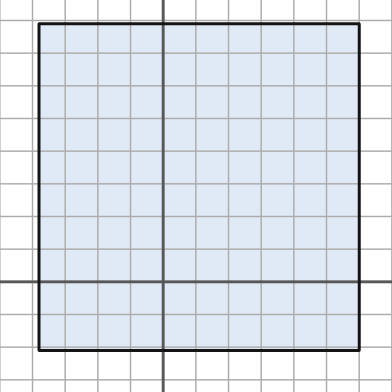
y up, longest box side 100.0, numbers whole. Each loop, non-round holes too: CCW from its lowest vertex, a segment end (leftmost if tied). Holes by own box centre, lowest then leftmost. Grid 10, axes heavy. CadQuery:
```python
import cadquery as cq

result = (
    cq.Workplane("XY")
    .moveTo(-38.0, -21.0)
    .lineTo(60.0, -21.0)
    .lineTo(60.0, 79.0)
    .lineTo(-38.0, 79.0)
    .close()
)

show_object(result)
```